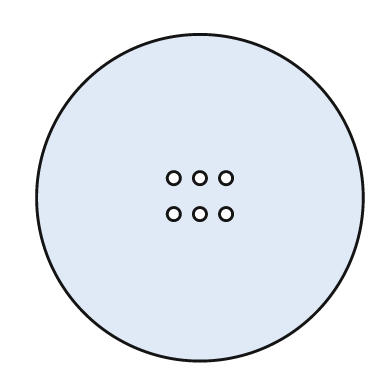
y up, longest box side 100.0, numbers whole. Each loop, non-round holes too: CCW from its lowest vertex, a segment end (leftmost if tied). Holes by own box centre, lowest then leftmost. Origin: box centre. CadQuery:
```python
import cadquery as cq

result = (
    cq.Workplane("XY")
    .moveTo(0.0, 0.0)
    .circle(50.0)
    .moveTo(-8.0, -5.0)
    .circle(2.0)
    .moveTo(0.0, -5.0)
    .circle(2.0)
    .moveTo(8.0, -5.0)
    .circle(2.0)
    .moveTo(-8.0, 6.0)
    .circle(2.0)
    .moveTo(0.0, 6.0)
    .circle(2.0)
    .moveTo(8.0, 6.0)
    .circle(2.0)
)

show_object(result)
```